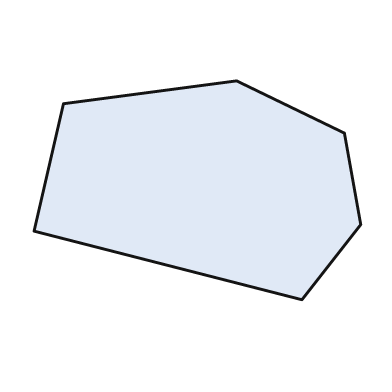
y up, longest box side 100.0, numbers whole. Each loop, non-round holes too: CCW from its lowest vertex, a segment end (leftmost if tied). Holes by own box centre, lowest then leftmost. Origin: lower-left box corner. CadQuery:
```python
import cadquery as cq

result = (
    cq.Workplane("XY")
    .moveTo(82.0, 0.0)
    .lineTo(100.0, 23.0)
    .lineTo(95.0, 51.0)
    .lineTo(62.0, 67.0)
    .lineTo(9.0, 60.0)
    .lineTo(0.0, 21.0)
    .close()
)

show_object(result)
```